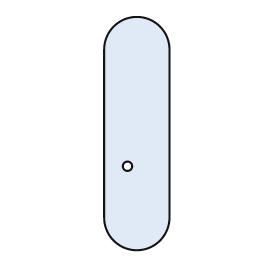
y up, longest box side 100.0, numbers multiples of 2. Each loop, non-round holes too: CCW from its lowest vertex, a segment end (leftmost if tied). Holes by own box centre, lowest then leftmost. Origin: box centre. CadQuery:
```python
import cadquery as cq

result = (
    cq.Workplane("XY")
    .moveTo(-14.0, -36.0)
    .threePointArc((0.0, -50.0), (14.0, -36.0))
    .lineTo(14.0, 36.0)
    .threePointArc((0.0, 50.0), (-14.0, 36.0))
    .close()
    .moveTo(-4.0, -14.0)
    .circle(2.0)
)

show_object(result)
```